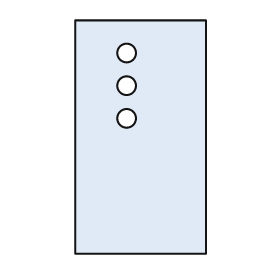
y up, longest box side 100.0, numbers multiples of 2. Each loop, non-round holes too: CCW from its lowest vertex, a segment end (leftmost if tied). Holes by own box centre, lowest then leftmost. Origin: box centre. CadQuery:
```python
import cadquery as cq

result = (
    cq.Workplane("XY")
    .moveTo(-28.0, -50.0)
    .lineTo(28.0, -50.0)
    .lineTo(28.0, 50.0)
    .lineTo(-28.0, 50.0)
    .close()
    .moveTo(-6.0, 8.0)
    .circle(4.0)
    .moveTo(-6.0, 22.0)
    .circle(4.0)
    .moveTo(-6.0, 36.0)
    .circle(4.0)
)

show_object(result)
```